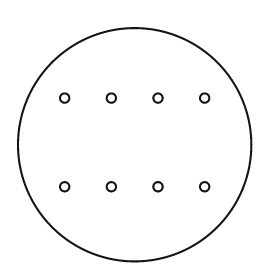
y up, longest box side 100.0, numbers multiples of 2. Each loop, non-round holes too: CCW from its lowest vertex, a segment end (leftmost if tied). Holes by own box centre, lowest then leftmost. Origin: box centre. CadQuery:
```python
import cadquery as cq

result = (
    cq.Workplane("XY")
    .moveTo(0.0, 0.0)
    .circle(50.0)
    .moveTo(-30.0, -18.0)
    .circle(2.0)
    .moveTo(-10.0, -18.0)
    .circle(2.0)
    .moveTo(10.0, -18.0)
    .circle(2.0)
    .moveTo(30.0, -18.0)
    .circle(2.0)
    .moveTo(-30.0, 20.0)
    .circle(2.0)
    .moveTo(-10.0, 20.0)
    .circle(2.0)
    .moveTo(10.0, 20.0)
    .circle(2.0)
    .moveTo(30.0, 20.0)
    .circle(2.0)
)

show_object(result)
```